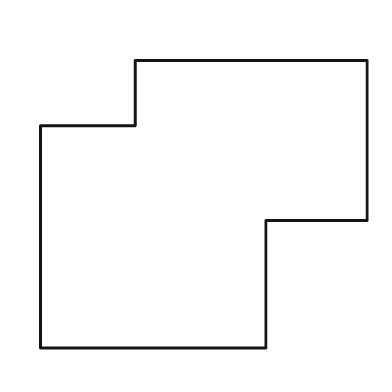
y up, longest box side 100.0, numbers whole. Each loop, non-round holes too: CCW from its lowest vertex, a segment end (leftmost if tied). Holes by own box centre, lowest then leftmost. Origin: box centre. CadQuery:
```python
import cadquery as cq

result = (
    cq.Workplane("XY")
    .moveTo(-50.0, -44.0)
    .lineTo(19.0, -44.0)
    .lineTo(19.0, -5.0)
    .lineTo(50.0, -5.0)
    .lineTo(50.0, 44.0)
    .lineTo(-21.0, 44.0)
    .lineTo(-21.0, 24.0)
    .lineTo(-50.0, 24.0)
    .close()
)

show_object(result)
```